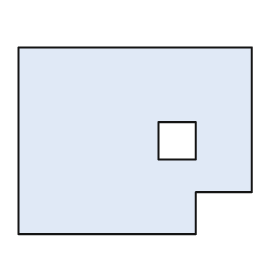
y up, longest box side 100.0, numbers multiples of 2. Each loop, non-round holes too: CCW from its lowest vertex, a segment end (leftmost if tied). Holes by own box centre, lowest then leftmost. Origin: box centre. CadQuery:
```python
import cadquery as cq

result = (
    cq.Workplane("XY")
    .moveTo(-50.0, -40.0)
    .lineTo(26.0, -40.0)
    .lineTo(26.0, -22.0)
    .lineTo(50.0, -22.0)
    .lineTo(50.0, 40.0)
    .lineTo(-50.0, 40.0)
    .close()
    .moveTo(10.0, -8.0)
    .lineTo(26.0, -8.0)
    .lineTo(26.0, 8.0)
    .lineTo(10.0, 8.0)
    .close()
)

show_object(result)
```